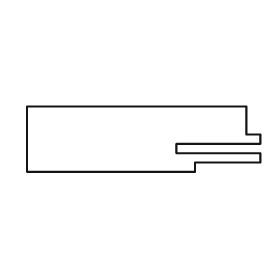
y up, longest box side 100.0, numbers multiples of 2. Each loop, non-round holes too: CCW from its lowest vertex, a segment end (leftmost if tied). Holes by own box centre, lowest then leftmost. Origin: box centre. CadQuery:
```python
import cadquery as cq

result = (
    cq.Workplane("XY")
    .moveTo(-50.0, -14.0)
    .lineTo(22.0, -14.0)
    .lineTo(22.0, -10.0)
    .lineTo(50.0, -10.0)
    .lineTo(50.0, -6.0)
    .lineTo(14.0, -6.0)
    .lineTo(14.0, -2.0)
    .lineTo(50.0, -2.0)
    .lineTo(50.0, 2.0)
    .lineTo(44.0, 2.0)
    .lineTo(44.0, 14.0)
    .lineTo(-50.0, 14.0)
    .close()
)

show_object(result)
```